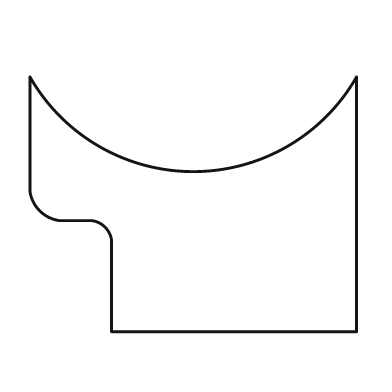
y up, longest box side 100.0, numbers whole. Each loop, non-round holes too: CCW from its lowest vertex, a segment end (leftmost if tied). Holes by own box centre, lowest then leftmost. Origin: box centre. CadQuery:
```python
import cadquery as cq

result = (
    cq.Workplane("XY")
    .moveTo(-25.0, -39.0)
    .lineTo(50.0, -39.0)
    .lineTo(50.0, 39.0)
    .threePointArc((0.0, 10.0), (-50.0, 39.0))
    .lineTo(-50.0, 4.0)
    .threePointArc((-47.0, -2.0), (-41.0, -5.0))
    .lineTo(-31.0, -5.0)
    .threePointArc((-27.0, -7.0), (-25.0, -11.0))
    .close()
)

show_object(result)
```